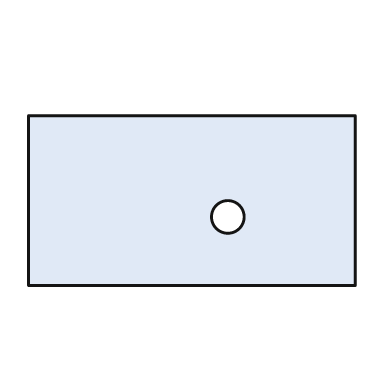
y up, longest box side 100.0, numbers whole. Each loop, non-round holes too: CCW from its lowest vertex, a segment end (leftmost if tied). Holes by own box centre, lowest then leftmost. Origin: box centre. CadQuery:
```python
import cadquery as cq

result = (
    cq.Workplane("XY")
    .moveTo(-50.0, -26.0)
    .lineTo(50.0, -26.0)
    .lineTo(50.0, 26.0)
    .lineTo(-50.0, 26.0)
    .close()
    .moveTo(11.0, -5.0)
    .circle(5.0)
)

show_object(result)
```